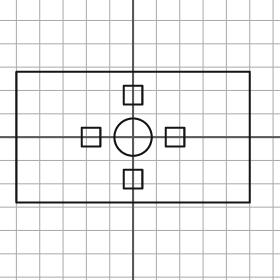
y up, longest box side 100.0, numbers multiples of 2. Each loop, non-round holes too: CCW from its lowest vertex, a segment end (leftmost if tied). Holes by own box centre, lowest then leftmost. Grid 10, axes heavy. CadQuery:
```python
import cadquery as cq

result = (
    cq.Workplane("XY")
    .moveTo(-50.0, -28.0)
    .lineTo(50.0, -28.0)
    .lineTo(50.0, 28.0)
    .lineTo(-50.0, 28.0)
    .close()
    .moveTo(-4.0, -22.0)
    .lineTo(4.0, -22.0)
    .lineTo(4.0, -14.0)
    .lineTo(-4.0, -14.0)
    .close()
    .moveTo(-22.0, -4.0)
    .lineTo(-14.0, -4.0)
    .lineTo(-14.0, 4.0)
    .lineTo(-22.0, 4.0)
    .close()
    .moveTo(0.0, 0.0)
    .circle(8.0)
    .moveTo(14.0, -4.0)
    .lineTo(22.0, -4.0)
    .lineTo(22.0, 4.0)
    .lineTo(14.0, 4.0)
    .close()
    .moveTo(-4.0, 14.0)
    .lineTo(4.0, 14.0)
    .lineTo(4.0, 22.0)
    .lineTo(-4.0, 22.0)
    .close()
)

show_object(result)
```